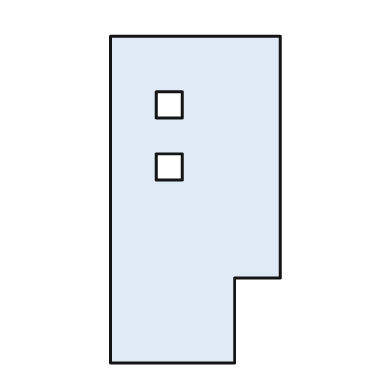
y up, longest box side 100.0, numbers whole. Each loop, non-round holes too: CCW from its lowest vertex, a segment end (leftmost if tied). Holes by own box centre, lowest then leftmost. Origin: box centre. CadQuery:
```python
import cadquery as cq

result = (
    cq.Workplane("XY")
    .moveTo(-26.0, -50.0)
    .lineTo(12.0, -50.0)
    .lineTo(12.0, -24.0)
    .lineTo(26.0, -24.0)
    .lineTo(26.0, 50.0)
    .lineTo(-26.0, 50.0)
    .close()
    .moveTo(-12.0, 6.0)
    .lineTo(-4.0, 6.0)
    .lineTo(-4.0, 14.0)
    .lineTo(-12.0, 14.0)
    .close()
    .moveTo(-12.0, 25.0)
    .lineTo(-4.0, 25.0)
    .lineTo(-4.0, 33.0)
    .lineTo(-12.0, 33.0)
    .close()
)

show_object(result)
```